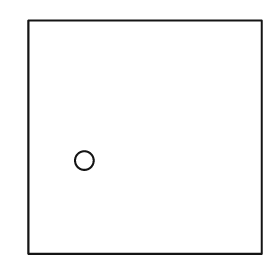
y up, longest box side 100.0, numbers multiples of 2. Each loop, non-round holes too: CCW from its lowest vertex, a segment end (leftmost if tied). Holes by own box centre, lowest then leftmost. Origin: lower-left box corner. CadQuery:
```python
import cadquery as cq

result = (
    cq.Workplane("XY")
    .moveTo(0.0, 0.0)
    .lineTo(100.0, 0.0)
    .lineTo(100.0, 100.0)
    .lineTo(0.0, 100.0)
    .close()
    .moveTo(24.0, 40.0)
    .circle(4.0)
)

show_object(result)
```